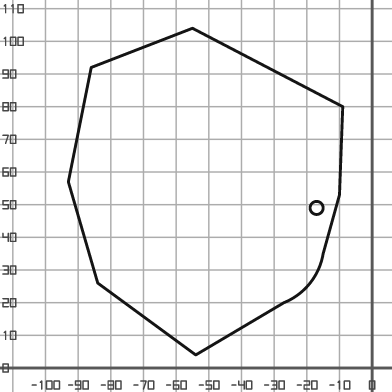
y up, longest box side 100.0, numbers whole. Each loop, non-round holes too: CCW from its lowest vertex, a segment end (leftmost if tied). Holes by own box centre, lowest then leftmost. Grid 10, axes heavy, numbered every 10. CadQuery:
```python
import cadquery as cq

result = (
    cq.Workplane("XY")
    .moveTo(-54.0, 4.0)
    .lineTo(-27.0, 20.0)
    .threePointArc((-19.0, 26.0), (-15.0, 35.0))
    .lineTo(-10.0, 53.0)
    .lineTo(-9.0, 80.0)
    .lineTo(-55.0, 104.0)
    .lineTo(-86.0, 92.0)
    .lineTo(-93.0, 57.0)
    .lineTo(-84.0, 26.0)
    .close()
    .moveTo(-17.0, 49.0)
    .circle(2.0)
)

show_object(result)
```